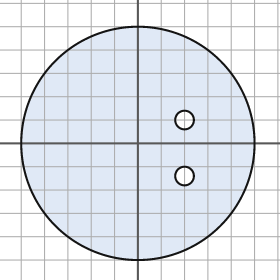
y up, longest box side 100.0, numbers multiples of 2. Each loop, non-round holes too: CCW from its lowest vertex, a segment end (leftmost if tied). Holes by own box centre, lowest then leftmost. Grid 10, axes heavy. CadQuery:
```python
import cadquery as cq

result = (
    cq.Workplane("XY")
    .moveTo(0.0, 0.0)
    .circle(50.0)
    .moveTo(20.0, -14.0)
    .circle(4.0)
    .moveTo(20.0, 10.0)
    .circle(4.0)
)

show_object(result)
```